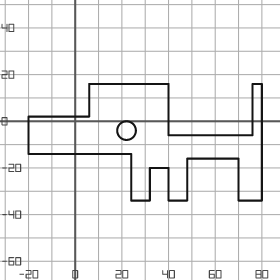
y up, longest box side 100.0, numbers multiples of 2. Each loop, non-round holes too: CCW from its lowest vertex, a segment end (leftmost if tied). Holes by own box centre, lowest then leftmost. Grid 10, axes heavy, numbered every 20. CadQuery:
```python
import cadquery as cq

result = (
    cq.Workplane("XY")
    .moveTo(24.0, -34.0)
    .lineTo(32.0, -34.0)
    .lineTo(32.0, -20.0)
    .lineTo(40.0, -20.0)
    .lineTo(40.0, -34.0)
    .lineTo(48.0, -34.0)
    .lineTo(48.0, -16.0)
    .lineTo(70.0, -16.0)
    .lineTo(70.0, -34.0)
    .lineTo(80.0, -34.0)
    .lineTo(80.0, 16.0)
    .lineTo(76.0, 16.0)
    .lineTo(76.0, -6.0)
    .lineTo(40.0, -6.0)
    .lineTo(40.0, 16.0)
    .lineTo(6.0, 16.0)
    .lineTo(6.0, 2.0)
    .lineTo(-20.0, 2.0)
    .lineTo(-20.0, -14.0)
    .lineTo(24.0, -14.0)
    .close()
    .moveTo(22.0, -4.0)
    .circle(4.0)
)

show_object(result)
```